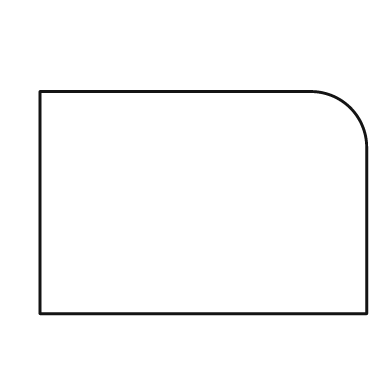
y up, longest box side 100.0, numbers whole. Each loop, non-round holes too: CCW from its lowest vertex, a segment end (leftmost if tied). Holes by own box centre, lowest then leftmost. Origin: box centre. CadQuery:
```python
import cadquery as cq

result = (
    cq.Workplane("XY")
    .moveTo(-50.0, -34.0)
    .lineTo(50.0, -34.0)
    .lineTo(50.0, 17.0)
    .threePointArc((45.0, 29.0), (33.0, 34.0))
    .lineTo(-50.0, 34.0)
    .close()
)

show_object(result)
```